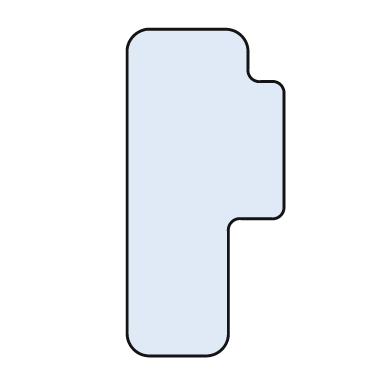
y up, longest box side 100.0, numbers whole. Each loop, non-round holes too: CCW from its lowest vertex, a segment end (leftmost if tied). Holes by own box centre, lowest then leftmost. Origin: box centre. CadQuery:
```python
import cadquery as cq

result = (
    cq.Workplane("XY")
    .moveTo(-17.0, -50.0)
    .lineTo(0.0, -50.0)
    .threePointArc((5.0, -48.0), (7.0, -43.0))
    .lineTo(7.0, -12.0)
    .threePointArc((8.0, -9.0), (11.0, -8.0))
    .lineTo(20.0, -8.0)
    .threePointArc((23.0, -7.0), (24.0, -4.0))
    .lineTo(24.0, 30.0)
    .threePointArc((23.0, 33.0), (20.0, 34.0))
    .lineTo(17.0, 34.0)
    .threePointArc((14.0, 35.0), (13.0, 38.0))
    .lineTo(13.0, 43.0)
    .threePointArc((11.0, 48.0), (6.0, 50.0))
    .lineTo(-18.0, 50.0)
    .threePointArc((-22.0, 48.0), (-24.0, 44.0))
    .lineTo(-24.0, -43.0)
    .threePointArc((-22.0, -48.0), (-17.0, -50.0))
    .close()
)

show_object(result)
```